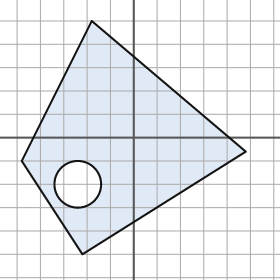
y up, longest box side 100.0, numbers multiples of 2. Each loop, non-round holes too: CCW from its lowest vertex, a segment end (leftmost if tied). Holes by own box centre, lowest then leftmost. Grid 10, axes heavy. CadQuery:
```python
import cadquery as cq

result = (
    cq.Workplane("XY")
    .moveTo(-22.0, -50.0)
    .lineTo(48.0, -6.0)
    .lineTo(-18.0, 50.0)
    .lineTo(-48.0, -10.0)
    .close()
    .moveTo(-24.0, -20.0)
    .circle(10.0)
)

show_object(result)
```